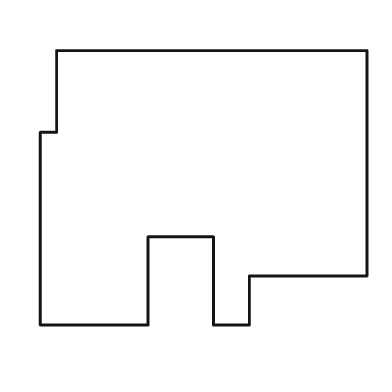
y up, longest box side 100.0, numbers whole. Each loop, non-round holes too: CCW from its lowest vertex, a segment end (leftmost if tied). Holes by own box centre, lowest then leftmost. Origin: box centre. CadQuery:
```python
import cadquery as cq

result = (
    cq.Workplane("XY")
    .moveTo(-50.0, -42.0)
    .lineTo(-17.0, -42.0)
    .lineTo(-17.0, -15.0)
    .lineTo(3.0, -15.0)
    .lineTo(3.0, -42.0)
    .lineTo(14.0, -42.0)
    .lineTo(14.0, -27.0)
    .lineTo(50.0, -27.0)
    .lineTo(50.0, 42.0)
    .lineTo(-45.0, 42.0)
    .lineTo(-45.0, 17.0)
    .lineTo(-50.0, 17.0)
    .close()
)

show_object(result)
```